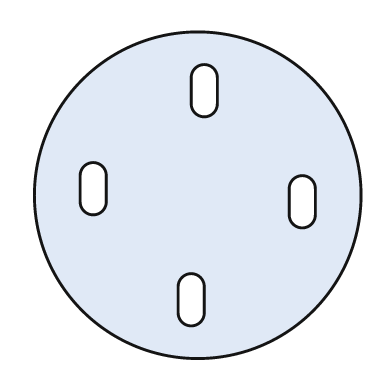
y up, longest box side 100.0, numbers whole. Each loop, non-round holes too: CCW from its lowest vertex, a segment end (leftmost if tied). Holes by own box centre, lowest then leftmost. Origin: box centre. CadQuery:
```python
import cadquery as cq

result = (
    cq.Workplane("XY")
    .moveTo(0.0, 0.0)
    .circle(50.0)
    .moveTo(-6.0, -36.0)
    .threePointArc((-2.0, -40.0), (2.0, -36.0))
    .lineTo(2.0, -28.0)
    .threePointArc((-2.0, -24.0), (-6.0, -28.0))
    .close()
    .moveTo(28.0, -6.0)
    .threePointArc((32.0, -10.0), (36.0, -6.0))
    .lineTo(36.0, 2.0)
    .threePointArc((32.0, 6.0), (28.0, 2.0))
    .close()
    .moveTo(-36.0, -2.0)
    .threePointArc((-32.0, -6.0), (-28.0, -2.0))
    .lineTo(-28.0, 6.0)
    .threePointArc((-32.0, 10.0), (-36.0, 6.0))
    .close()
    .moveTo(-2.0, 28.0)
    .threePointArc((2.0, 24.0), (6.0, 28.0))
    .lineTo(6.0, 36.0)
    .threePointArc((2.0, 40.0), (-2.0, 36.0))
    .close()
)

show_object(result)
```